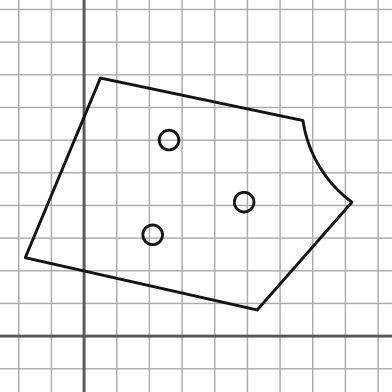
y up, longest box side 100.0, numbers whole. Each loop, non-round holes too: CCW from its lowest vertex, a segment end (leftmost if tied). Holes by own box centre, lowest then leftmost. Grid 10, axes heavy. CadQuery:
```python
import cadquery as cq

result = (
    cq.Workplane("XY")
    .moveTo(53.0, 8.0)
    .lineTo(82.0, 41.0)
    .threePointArc((72.0, 52.0), (67.0, 66.0))
    .lineTo(5.0, 79.0)
    .lineTo(-18.0, 24.0)
    .close()
    .moveTo(21.0, 31.0)
    .circle(3.0)
    .moveTo(49.0, 41.0)
    .circle(3.0)
    .moveTo(26.0, 60.0)
    .circle(3.0)
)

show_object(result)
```